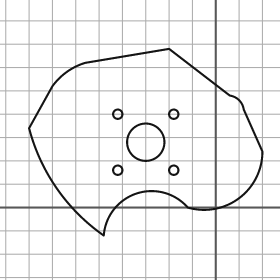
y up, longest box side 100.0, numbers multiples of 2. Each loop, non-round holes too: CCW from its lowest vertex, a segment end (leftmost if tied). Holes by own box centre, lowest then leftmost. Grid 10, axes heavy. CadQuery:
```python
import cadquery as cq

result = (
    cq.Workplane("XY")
    .moveTo(-48.0, -12.0)
    .threePointArc((-34.0, 6.0), (-12.0, 0.0))
    .threePointArc((10.0, 4.0), (20.0, 24.0))
    .lineTo(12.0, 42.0)
    .threePointArc((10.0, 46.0), (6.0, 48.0))
    .lineTo(-20.0, 68.0)
    .lineTo(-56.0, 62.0)
    .threePointArc((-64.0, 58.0), (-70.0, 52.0))
    .lineTo(-80.0, 34.0)
    .threePointArc((-68.0, 8.0), (-48.0, -12.0))
    .close()
    .moveTo(-42.0, 16.0)
    .circle(2.0)
    .moveTo(-18.0, 16.0)
    .circle(2.0)
    .moveTo(-30.0, 28.0)
    .circle(8.0)
    .moveTo(-42.0, 40.0)
    .circle(2.0)
    .moveTo(-18.0, 40.0)
    .circle(2.0)
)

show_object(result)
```